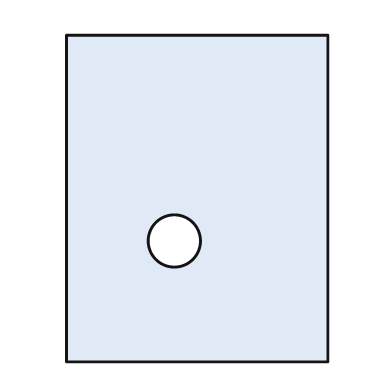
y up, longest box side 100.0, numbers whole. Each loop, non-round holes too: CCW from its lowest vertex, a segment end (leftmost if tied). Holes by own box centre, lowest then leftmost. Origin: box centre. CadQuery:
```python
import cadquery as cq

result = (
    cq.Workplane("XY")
    .moveTo(-40.0, -50.0)
    .lineTo(40.0, -50.0)
    .lineTo(40.0, 50.0)
    .lineTo(-40.0, 50.0)
    .close()
    .moveTo(-7.0, -13.0)
    .circle(8.0)
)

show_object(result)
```